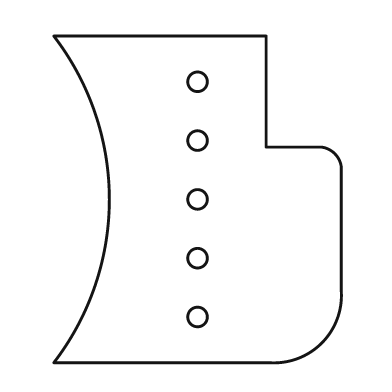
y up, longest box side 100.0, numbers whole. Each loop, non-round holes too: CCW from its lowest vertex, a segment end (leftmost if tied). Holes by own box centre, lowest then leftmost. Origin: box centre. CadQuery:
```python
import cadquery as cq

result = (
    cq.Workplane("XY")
    .moveTo(-44.0, -50.0)
    .lineTo(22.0, -50.0)
    .threePointArc((38.0, -44.0), (44.0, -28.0))
    .lineTo(44.0, 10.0)
    .threePointArc((42.0, 14.0), (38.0, 16.0))
    .lineTo(21.0, 16.0)
    .lineTo(21.0, 50.0)
    .lineTo(-44.0, 50.0)
    .threePointArc((-27.0, 0.0), (-44.0, -50.0))
    .close()
    .moveTo(0.0, -36.0)
    .circle(3.0)
    .moveTo(0.0, -18.0)
    .circle(3.0)
    .moveTo(0.0, 0.0)
    .circle(3.0)
    .moveTo(0.0, 18.0)
    .circle(3.0)
    .moveTo(0.0, 36.0)
    .circle(3.0)
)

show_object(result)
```